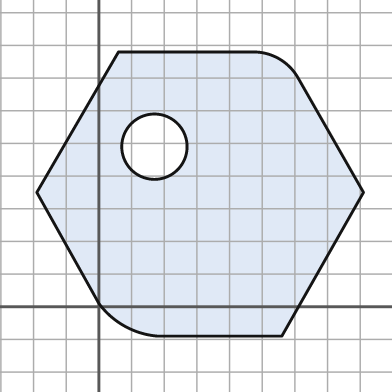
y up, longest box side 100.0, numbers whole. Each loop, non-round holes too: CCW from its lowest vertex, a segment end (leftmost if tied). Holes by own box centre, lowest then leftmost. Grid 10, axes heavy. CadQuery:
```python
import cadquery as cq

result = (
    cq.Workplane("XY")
    .moveTo(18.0, -9.0)
    .lineTo(56.0, -9.0)
    .lineTo(81.0, 35.0)
    .lineTo(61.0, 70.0)
    .threePointArc((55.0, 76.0), (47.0, 78.0))
    .lineTo(6.0, 78.0)
    .lineTo(-19.0, 35.0)
    .lineTo(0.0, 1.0)
    .threePointArc((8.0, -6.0), (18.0, -9.0))
    .close()
    .moveTo(17.0, 49.0)
    .circle(10.0)
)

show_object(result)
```